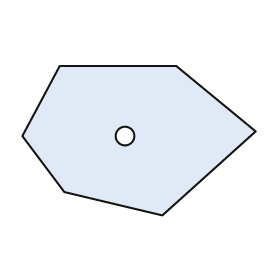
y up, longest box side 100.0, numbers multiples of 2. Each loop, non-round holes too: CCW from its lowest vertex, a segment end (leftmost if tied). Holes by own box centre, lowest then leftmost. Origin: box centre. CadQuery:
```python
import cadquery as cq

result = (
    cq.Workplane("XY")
    .moveTo(10.0, -32.0)
    .lineTo(50.0, 4.0)
    .lineTo(16.0, 32.0)
    .lineTo(-34.0, 32.0)
    .lineTo(-50.0, 2.0)
    .lineTo(-32.0, -22.0)
    .close()
    .moveTo(-6.0, 2.0)
    .circle(4.0)
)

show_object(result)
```